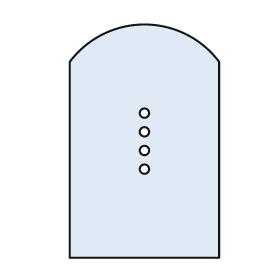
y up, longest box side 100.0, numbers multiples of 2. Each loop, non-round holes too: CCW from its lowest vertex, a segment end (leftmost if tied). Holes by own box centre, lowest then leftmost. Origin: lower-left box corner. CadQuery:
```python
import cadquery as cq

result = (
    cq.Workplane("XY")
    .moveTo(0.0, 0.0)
    .lineTo(64.0, 0.0)
    .lineTo(64.0, 84.0)
    .threePointArc((32.0, 100.0), (0.0, 84.0))
    .close()
    .moveTo(32.0, 38.0)
    .circle(2.0)
    .moveTo(32.0, 46.0)
    .circle(2.0)
    .moveTo(32.0, 54.0)
    .circle(2.0)
    .moveTo(32.0, 62.0)
    .circle(2.0)
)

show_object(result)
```